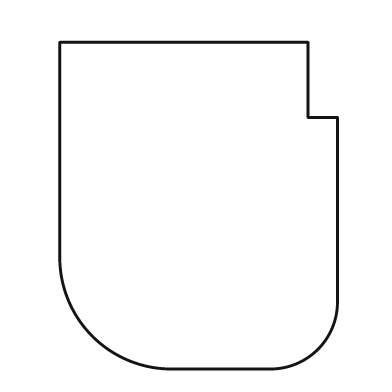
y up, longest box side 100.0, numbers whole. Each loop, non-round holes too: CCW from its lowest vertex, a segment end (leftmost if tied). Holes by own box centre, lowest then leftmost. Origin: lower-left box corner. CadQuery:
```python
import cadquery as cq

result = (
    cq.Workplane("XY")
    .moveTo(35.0, 0.0)
    .lineTo(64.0, 0.0)
    .threePointArc((79.0, 6.0), (85.0, 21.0))
    .lineTo(85.0, 77.0)
    .lineTo(76.0, 77.0)
    .lineTo(76.0, 100.0)
    .lineTo(0.0, 100.0)
    .lineTo(0.0, 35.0)
    .threePointArc((10.0, 10.0), (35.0, 0.0))
    .close()
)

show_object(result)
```